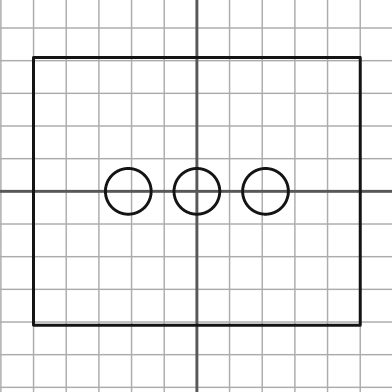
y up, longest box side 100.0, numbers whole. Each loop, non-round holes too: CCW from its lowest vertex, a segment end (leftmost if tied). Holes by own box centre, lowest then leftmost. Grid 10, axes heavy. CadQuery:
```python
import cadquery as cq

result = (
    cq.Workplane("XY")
    .moveTo(-50.0, -41.0)
    .lineTo(50.0, -41.0)
    .lineTo(50.0, 41.0)
    .lineTo(-50.0, 41.0)
    .close()
    .moveTo(-21.0, 0.0)
    .circle(7.0)
    .moveTo(0.0, 0.0)
    .circle(7.0)
    .moveTo(21.0, 0.0)
    .circle(7.0)
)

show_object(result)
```